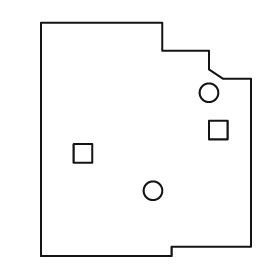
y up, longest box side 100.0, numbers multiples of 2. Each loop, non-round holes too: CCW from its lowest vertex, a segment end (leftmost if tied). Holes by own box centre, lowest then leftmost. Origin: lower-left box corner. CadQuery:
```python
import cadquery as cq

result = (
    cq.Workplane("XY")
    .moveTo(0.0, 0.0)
    .lineTo(56.0, 0.0)
    .lineTo(56.0, 4.0)
    .lineTo(90.0, 4.0)
    .lineTo(90.0, 76.0)
    .lineTo(78.0, 76.0)
    .lineTo(72.0, 80.0)
    .lineTo(72.0, 88.0)
    .lineTo(52.0, 88.0)
    .lineTo(52.0, 100.0)
    .lineTo(0.0, 100.0)
    .close()
    .moveTo(48.0, 28.0)
    .circle(4.0)
    .moveTo(14.0, 40.0)
    .lineTo(22.0, 40.0)
    .lineTo(22.0, 48.0)
    .lineTo(14.0, 48.0)
    .close()
    .moveTo(72.0, 50.0)
    .lineTo(80.0, 50.0)
    .lineTo(80.0, 58.0)
    .lineTo(72.0, 58.0)
    .close()
    .moveTo(72.0, 70.0)
    .circle(4.0)
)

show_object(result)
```